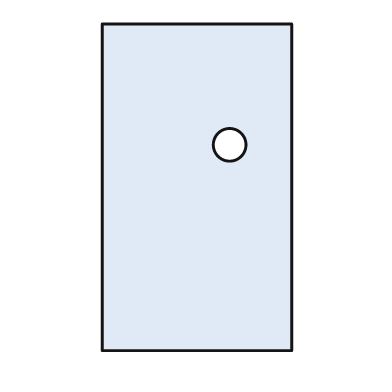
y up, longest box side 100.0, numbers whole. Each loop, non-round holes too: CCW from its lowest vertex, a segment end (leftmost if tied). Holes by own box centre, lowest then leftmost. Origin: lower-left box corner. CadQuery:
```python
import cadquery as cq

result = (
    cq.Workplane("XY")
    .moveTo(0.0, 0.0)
    .lineTo(58.0, 0.0)
    .lineTo(58.0, 100.0)
    .lineTo(0.0, 100.0)
    .close()
    .moveTo(39.0, 63.0)
    .circle(5.0)
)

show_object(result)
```